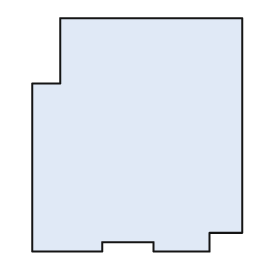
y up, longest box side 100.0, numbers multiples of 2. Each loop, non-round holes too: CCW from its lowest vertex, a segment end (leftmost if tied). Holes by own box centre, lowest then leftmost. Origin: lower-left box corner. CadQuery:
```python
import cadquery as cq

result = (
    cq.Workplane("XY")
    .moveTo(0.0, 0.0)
    .lineTo(30.0, 0.0)
    .lineTo(30.0, 4.0)
    .lineTo(52.0, 4.0)
    .lineTo(52.0, 0.0)
    .lineTo(76.0, 0.0)
    .lineTo(76.0, 8.0)
    .lineTo(90.0, 8.0)
    .lineTo(90.0, 100.0)
    .lineTo(12.0, 100.0)
    .lineTo(12.0, 72.0)
    .lineTo(0.0, 72.0)
    .close()
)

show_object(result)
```